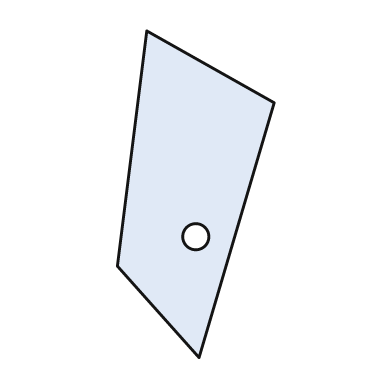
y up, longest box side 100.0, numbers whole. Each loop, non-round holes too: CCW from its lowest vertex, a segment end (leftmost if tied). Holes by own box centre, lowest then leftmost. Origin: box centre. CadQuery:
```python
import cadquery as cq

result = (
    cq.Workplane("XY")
    .moveTo(1.0, -50.0)
    .lineTo(24.0, 28.0)
    .lineTo(-15.0, 50.0)
    .lineTo(-24.0, -22.0)
    .close()
    .moveTo(0.0, -13.0)
    .circle(4.0)
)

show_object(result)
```